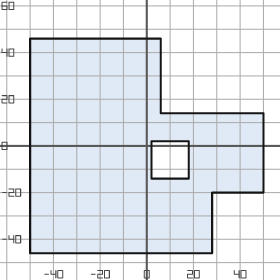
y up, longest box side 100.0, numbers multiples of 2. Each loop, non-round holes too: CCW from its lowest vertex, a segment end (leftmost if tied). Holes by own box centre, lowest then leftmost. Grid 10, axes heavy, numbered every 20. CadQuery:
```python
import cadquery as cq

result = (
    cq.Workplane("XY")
    .moveTo(-50.0, -46.0)
    .lineTo(28.0, -46.0)
    .lineTo(28.0, -20.0)
    .lineTo(50.0, -20.0)
    .lineTo(50.0, 14.0)
    .lineTo(6.0, 14.0)
    .lineTo(6.0, 46.0)
    .lineTo(-50.0, 46.0)
    .close()
    .moveTo(2.0, -14.0)
    .lineTo(18.0, -14.0)
    .lineTo(18.0, 2.0)
    .lineTo(2.0, 2.0)
    .close()
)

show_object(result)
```